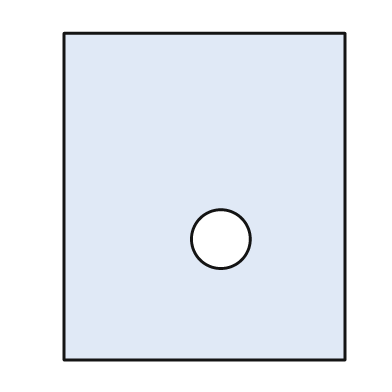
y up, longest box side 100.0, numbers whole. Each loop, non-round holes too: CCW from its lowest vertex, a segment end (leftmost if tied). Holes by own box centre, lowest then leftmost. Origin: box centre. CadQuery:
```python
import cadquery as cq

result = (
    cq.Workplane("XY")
    .moveTo(-43.0, -50.0)
    .lineTo(43.0, -50.0)
    .lineTo(43.0, 50.0)
    .lineTo(-43.0, 50.0)
    .close()
    .moveTo(5.0, -13.0)
    .circle(9.0)
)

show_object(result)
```